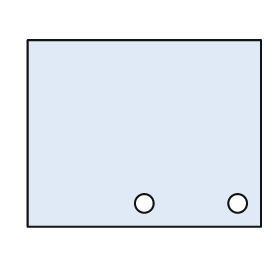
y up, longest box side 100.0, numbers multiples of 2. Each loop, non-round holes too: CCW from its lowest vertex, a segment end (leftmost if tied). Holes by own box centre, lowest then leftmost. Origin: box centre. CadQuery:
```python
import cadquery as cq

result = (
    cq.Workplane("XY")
    .moveTo(-50.0, -40.0)
    .lineTo(50.0, -40.0)
    .lineTo(50.0, 40.0)
    .lineTo(-50.0, 40.0)
    .close()
    .moveTo(0.0, -30.0)
    .circle(4.0)
    .moveTo(40.0, -30.0)
    .circle(4.0)
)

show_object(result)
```